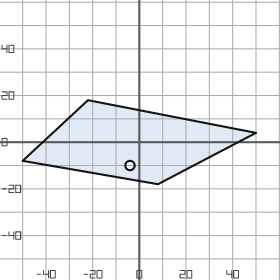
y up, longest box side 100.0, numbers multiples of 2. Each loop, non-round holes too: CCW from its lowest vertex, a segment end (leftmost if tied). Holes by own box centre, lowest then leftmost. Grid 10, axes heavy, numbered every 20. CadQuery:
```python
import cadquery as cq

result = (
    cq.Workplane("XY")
    .moveTo(8.0, -18.0)
    .lineTo(50.0, 4.0)
    .lineTo(-22.0, 18.0)
    .lineTo(-50.0, -8.0)
    .close()
    .moveTo(-4.0, -10.0)
    .circle(2.0)
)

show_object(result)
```